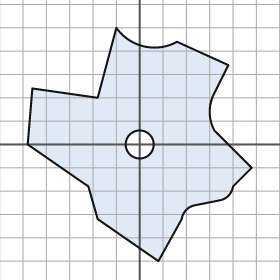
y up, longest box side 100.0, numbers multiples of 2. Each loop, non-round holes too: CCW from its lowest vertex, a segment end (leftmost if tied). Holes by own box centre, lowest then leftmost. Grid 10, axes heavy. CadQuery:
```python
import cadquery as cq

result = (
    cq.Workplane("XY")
    .moveTo(8.0, -50.0)
    .lineTo(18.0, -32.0)
    .threePointArc((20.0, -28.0), (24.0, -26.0))
    .lineTo(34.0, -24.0)
    .threePointArc((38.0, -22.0), (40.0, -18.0))
    .lineTo(48.0, -10.0)
    .lineTo(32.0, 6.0)
    .threePointArc((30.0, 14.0), (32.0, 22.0))
    .lineTo(38.0, 34.0)
    .lineTo(16.0, 44.0)
    .threePointArc((2.0, 42.0), (-10.0, 50.0))
    .lineTo(-18.0, 20.0)
    .lineTo(-46.0, 24.0)
    .lineTo(-48.0, 0.0)
    .lineTo(-22.0, -18.0)
    .lineTo(-18.0, -32.0)
    .close()
    .moveTo(0.0, 0.0)
    .circle(6.0)
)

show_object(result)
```